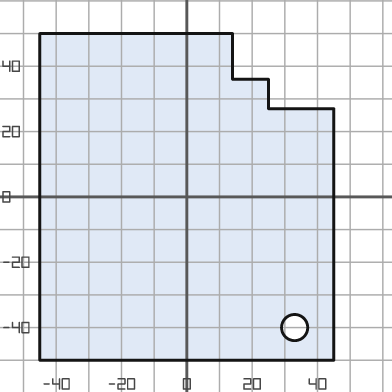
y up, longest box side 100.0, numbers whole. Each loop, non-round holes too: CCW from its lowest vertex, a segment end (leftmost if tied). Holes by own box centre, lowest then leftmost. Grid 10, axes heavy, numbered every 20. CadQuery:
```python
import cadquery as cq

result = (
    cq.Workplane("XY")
    .moveTo(-45.0, -50.0)
    .lineTo(45.0, -50.0)
    .lineTo(45.0, 27.0)
    .lineTo(25.0, 27.0)
    .lineTo(25.0, 36.0)
    .lineTo(14.0, 36.0)
    .lineTo(14.0, 50.0)
    .lineTo(-45.0, 50.0)
    .close()
    .moveTo(33.0, -40.0)
    .circle(4.0)
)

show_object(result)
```